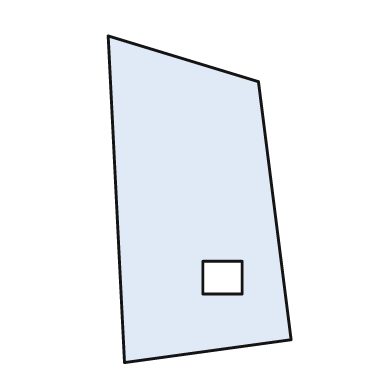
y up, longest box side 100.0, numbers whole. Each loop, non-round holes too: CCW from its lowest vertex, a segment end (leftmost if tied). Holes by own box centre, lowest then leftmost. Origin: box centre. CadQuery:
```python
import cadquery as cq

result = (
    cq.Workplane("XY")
    .moveTo(-23.0, -50.0)
    .lineTo(28.0, -43.0)
    .lineTo(18.0, 36.0)
    .lineTo(-28.0, 50.0)
    .close()
    .moveTo(1.0, -29.0)
    .lineTo(13.0, -29.0)
    .lineTo(13.0, -19.0)
    .lineTo(1.0, -19.0)
    .close()
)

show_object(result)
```